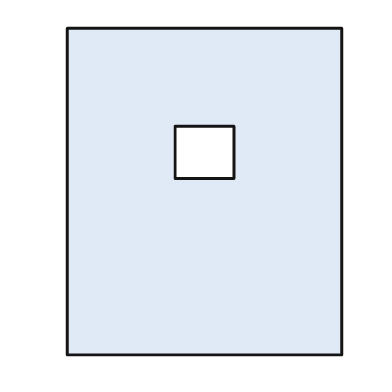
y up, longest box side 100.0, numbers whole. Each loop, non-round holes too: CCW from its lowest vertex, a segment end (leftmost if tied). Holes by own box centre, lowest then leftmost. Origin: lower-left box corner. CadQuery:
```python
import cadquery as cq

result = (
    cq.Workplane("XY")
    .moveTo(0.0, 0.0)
    .lineTo(84.0, 0.0)
    .lineTo(84.0, 100.0)
    .lineTo(0.0, 100.0)
    .close()
    .moveTo(33.0, 54.0)
    .lineTo(51.0, 54.0)
    .lineTo(51.0, 70.0)
    .lineTo(33.0, 70.0)
    .close()
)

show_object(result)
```